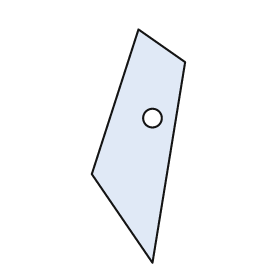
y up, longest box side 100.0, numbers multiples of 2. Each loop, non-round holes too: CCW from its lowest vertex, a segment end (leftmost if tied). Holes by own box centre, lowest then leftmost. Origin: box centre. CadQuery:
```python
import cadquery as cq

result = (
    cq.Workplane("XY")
    .moveTo(6.0, -50.0)
    .lineTo(20.0, 36.0)
    .lineTo(0.0, 50.0)
    .lineTo(-20.0, -12.0)
    .close()
    .moveTo(6.0, 12.0)
    .circle(4.0)
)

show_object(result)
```